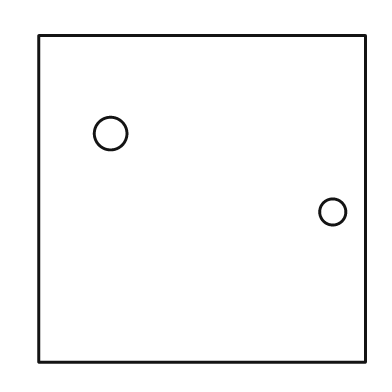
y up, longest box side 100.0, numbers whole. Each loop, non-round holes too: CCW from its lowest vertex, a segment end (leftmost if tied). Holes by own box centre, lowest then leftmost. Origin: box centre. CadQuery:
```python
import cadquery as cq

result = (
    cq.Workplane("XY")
    .moveTo(-50.0, -50.0)
    .lineTo(50.0, -50.0)
    .lineTo(50.0, 50.0)
    .lineTo(-50.0, 50.0)
    .close()
    .moveTo(40.0, -4.0)
    .circle(4.0)
    .moveTo(-28.0, 20.0)
    .circle(5.0)
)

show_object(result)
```